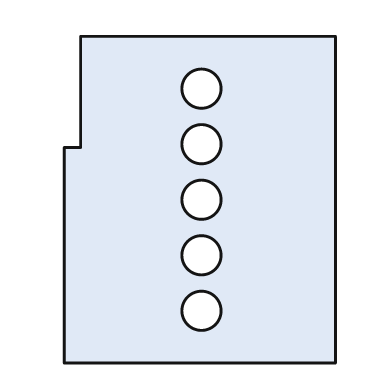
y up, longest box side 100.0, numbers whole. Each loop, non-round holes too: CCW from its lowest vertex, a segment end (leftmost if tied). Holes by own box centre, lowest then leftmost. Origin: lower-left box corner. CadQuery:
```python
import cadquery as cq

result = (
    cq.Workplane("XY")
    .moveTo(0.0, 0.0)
    .lineTo(83.0, 0.0)
    .lineTo(83.0, 100.0)
    .lineTo(5.0, 100.0)
    .lineTo(5.0, 66.0)
    .lineTo(0.0, 66.0)
    .close()
    .moveTo(42.0, 16.0)
    .circle(6.0)
    .moveTo(42.0, 33.0)
    .circle(6.0)
    .moveTo(42.0, 50.0)
    .circle(6.0)
    .moveTo(42.0, 67.0)
    .circle(6.0)
    .moveTo(42.0, 84.0)
    .circle(6.0)
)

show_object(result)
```